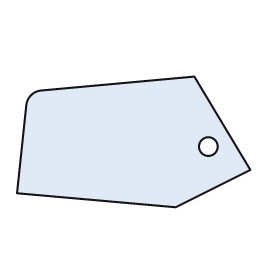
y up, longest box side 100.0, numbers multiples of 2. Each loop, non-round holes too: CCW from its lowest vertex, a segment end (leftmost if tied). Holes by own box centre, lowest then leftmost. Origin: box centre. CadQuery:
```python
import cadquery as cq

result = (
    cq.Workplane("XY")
    .moveTo(18.0, -28.0)
    .lineTo(50.0, -12.0)
    .lineTo(26.0, 28.0)
    .lineTo(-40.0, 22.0)
    .threePointArc((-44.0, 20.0), (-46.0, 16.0))
    .lineTo(-50.0, -22.0)
    .close()
    .moveTo(32.0, -2.0)
    .circle(4.0)
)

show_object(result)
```